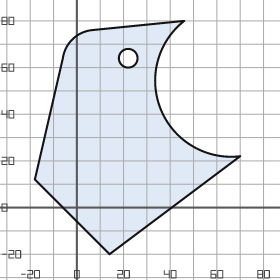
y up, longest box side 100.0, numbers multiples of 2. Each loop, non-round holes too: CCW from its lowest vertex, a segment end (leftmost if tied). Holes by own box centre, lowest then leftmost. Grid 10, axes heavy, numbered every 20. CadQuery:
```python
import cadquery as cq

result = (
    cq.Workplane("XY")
    .moveTo(14.0, -20.0)
    .lineTo(70.0, 22.0)
    .threePointArc((36.0, 42.0), (46.0, 80.0))
    .lineTo(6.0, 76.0)
    .threePointArc((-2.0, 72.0), (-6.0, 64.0))
    .lineTo(-18.0, 12.0)
    .close()
    .moveTo(22.0, 64.0)
    .circle(4.0)
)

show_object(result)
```